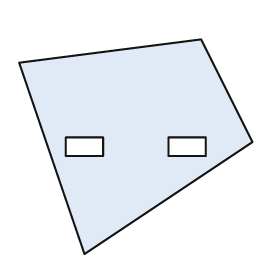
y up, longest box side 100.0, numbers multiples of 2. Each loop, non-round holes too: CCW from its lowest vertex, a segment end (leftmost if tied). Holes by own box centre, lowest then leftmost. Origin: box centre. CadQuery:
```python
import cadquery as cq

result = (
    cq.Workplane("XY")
    .moveTo(-22.0, -46.0)
    .lineTo(50.0, 2.0)
    .lineTo(28.0, 46.0)
    .lineTo(-50.0, 36.0)
    .close()
    .moveTo(-30.0, -4.0)
    .lineTo(-14.0, -4.0)
    .lineTo(-14.0, 4.0)
    .lineTo(-30.0, 4.0)
    .close()
    .moveTo(14.0, -4.0)
    .lineTo(30.0, -4.0)
    .lineTo(30.0, 4.0)
    .lineTo(14.0, 4.0)
    .close()
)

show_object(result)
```